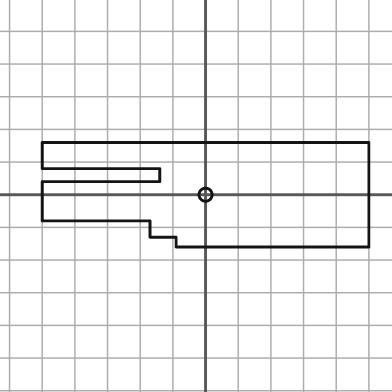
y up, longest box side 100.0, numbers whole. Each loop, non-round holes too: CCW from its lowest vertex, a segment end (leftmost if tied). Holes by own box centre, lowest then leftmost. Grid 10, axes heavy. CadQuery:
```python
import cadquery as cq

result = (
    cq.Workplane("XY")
    .moveTo(-9.0, -16.0)
    .lineTo(50.0, -16.0)
    .lineTo(50.0, 16.0)
    .lineTo(-50.0, 16.0)
    .lineTo(-50.0, 8.0)
    .lineTo(-14.0, 8.0)
    .lineTo(-14.0, 4.0)
    .lineTo(-50.0, 4.0)
    .lineTo(-50.0, -8.0)
    .lineTo(-17.0, -8.0)
    .lineTo(-17.0, -13.0)
    .lineTo(-9.0, -13.0)
    .close()
    .moveTo(0.0, 0.0)
    .circle(2.0)
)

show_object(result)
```